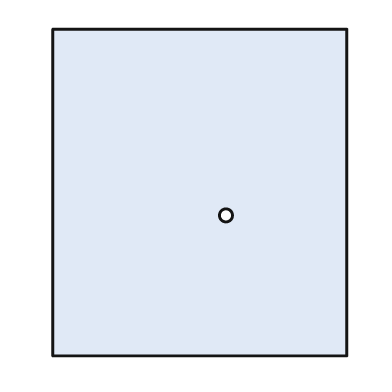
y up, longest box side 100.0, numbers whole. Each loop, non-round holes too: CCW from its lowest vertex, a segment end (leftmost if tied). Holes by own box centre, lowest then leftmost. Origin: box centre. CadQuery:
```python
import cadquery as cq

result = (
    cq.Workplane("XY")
    .moveTo(-45.0, -50.0)
    .lineTo(45.0, -50.0)
    .lineTo(45.0, 50.0)
    .lineTo(-45.0, 50.0)
    .close()
    .moveTo(8.0, -7.0)
    .circle(2.0)
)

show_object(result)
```